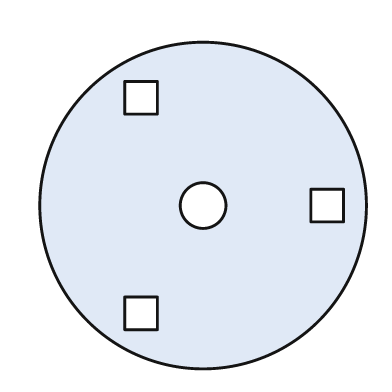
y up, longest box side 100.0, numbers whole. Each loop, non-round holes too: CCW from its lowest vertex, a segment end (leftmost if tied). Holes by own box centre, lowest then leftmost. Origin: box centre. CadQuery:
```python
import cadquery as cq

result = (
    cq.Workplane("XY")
    .moveTo(0.0, 0.0)
    .circle(50.0)
    .moveTo(-24.0, -38.0)
    .lineTo(-14.0, -38.0)
    .lineTo(-14.0, -28.0)
    .lineTo(-24.0, -28.0)
    .close()
    .moveTo(0.0, 0.0)
    .circle(7.0)
    .moveTo(33.0, -5.0)
    .lineTo(43.0, -5.0)
    .lineTo(43.0, 5.0)
    .lineTo(33.0, 5.0)
    .close()
    .moveTo(-24.0, 28.0)
    .lineTo(-14.0, 28.0)
    .lineTo(-14.0, 38.0)
    .lineTo(-24.0, 38.0)
    .close()
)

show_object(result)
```